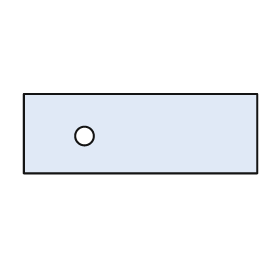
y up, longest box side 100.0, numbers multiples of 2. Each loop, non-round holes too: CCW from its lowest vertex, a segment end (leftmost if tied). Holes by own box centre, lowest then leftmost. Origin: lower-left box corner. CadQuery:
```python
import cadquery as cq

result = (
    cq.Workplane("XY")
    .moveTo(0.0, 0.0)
    .lineTo(100.0, 0.0)
    .lineTo(100.0, 34.0)
    .lineTo(0.0, 34.0)
    .close()
    .moveTo(26.0, 16.0)
    .circle(4.0)
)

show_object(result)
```